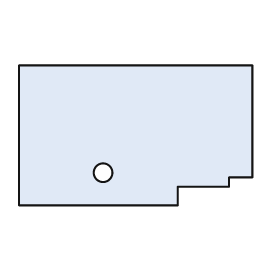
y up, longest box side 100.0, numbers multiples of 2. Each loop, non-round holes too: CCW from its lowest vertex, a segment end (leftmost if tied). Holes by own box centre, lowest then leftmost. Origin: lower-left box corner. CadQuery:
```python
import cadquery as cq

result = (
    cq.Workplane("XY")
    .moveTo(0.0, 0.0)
    .lineTo(68.0, 0.0)
    .lineTo(68.0, 8.0)
    .lineTo(90.0, 8.0)
    .lineTo(90.0, 12.0)
    .lineTo(100.0, 12.0)
    .lineTo(100.0, 60.0)
    .lineTo(0.0, 60.0)
    .close()
    .moveTo(36.0, 14.0)
    .circle(4.0)
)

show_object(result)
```